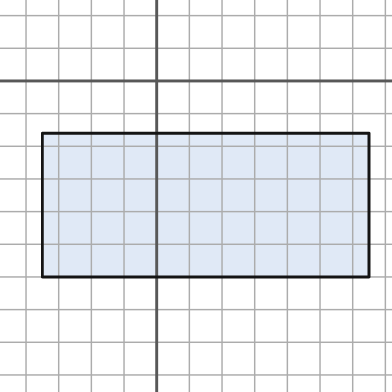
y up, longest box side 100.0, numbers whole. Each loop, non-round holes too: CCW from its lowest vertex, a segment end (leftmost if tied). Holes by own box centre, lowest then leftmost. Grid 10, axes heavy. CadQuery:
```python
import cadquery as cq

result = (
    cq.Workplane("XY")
    .moveTo(-35.0, -60.0)
    .lineTo(65.0, -60.0)
    .lineTo(65.0, -16.0)
    .lineTo(-35.0, -16.0)
    .close()
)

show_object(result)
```